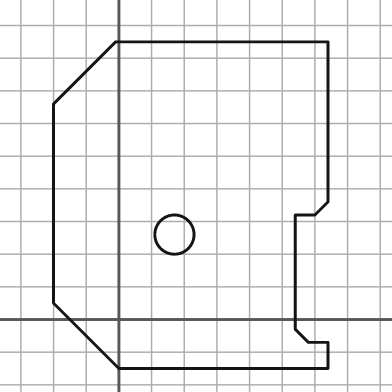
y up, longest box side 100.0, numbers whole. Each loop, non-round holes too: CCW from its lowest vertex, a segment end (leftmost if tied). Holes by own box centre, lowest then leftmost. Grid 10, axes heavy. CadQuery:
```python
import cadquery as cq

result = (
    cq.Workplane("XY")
    .moveTo(0.0, -15.0)
    .lineTo(64.0, -15.0)
    .lineTo(64.0, -7.0)
    .lineTo(58.0, -7.0)
    .lineTo(54.0, -3.0)
    .lineTo(54.0, 32.0)
    .lineTo(60.0, 32.0)
    .lineTo(64.0, 36.0)
    .lineTo(64.0, 85.0)
    .lineTo(-1.0, 85.0)
    .lineTo(-20.0, 66.0)
    .lineTo(-20.0, 5.0)
    .close()
    .moveTo(17.0, 26.0)
    .circle(6.0)
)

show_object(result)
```